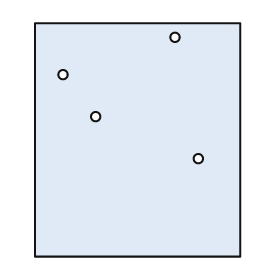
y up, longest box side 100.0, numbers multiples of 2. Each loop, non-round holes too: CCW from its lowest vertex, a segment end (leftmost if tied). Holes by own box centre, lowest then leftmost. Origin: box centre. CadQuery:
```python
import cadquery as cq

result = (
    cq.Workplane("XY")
    .moveTo(-44.0, -50.0)
    .lineTo(44.0, -50.0)
    .lineTo(44.0, 50.0)
    .lineTo(-44.0, 50.0)
    .close()
    .moveTo(26.0, -8.0)
    .circle(2.0)
    .moveTo(-18.0, 10.0)
    .circle(2.0)
    .moveTo(-32.0, 28.0)
    .circle(2.0)
    .moveTo(16.0, 44.0)
    .circle(2.0)
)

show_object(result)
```